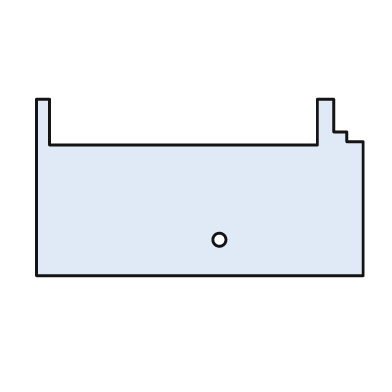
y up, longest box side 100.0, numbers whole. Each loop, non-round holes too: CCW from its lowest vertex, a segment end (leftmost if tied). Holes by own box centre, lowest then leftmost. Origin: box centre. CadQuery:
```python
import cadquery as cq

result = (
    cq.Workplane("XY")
    .moveTo(-50.0, -27.0)
    .lineTo(50.0, -27.0)
    .lineTo(50.0, 14.0)
    .lineTo(45.0, 14.0)
    .lineTo(45.0, 17.0)
    .lineTo(41.0, 17.0)
    .lineTo(41.0, 27.0)
    .lineTo(36.0, 27.0)
    .lineTo(36.0, 13.0)
    .lineTo(-46.0, 13.0)
    .lineTo(-46.0, 27.0)
    .lineTo(-50.0, 27.0)
    .close()
    .moveTo(6.0, -16.0)
    .circle(2.0)
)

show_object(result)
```